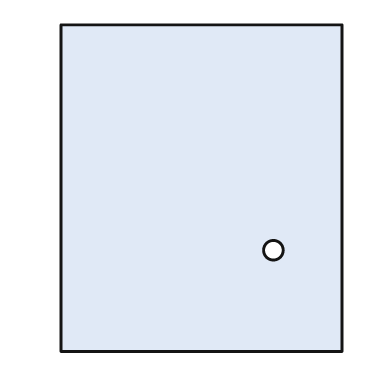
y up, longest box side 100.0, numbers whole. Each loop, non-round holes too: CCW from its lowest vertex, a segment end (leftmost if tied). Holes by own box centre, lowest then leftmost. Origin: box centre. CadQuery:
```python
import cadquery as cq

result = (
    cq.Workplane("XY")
    .moveTo(-43.0, -50.0)
    .lineTo(43.0, -50.0)
    .lineTo(43.0, 50.0)
    .lineTo(-43.0, 50.0)
    .close()
    .moveTo(22.0, -19.0)
    .circle(3.0)
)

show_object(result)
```